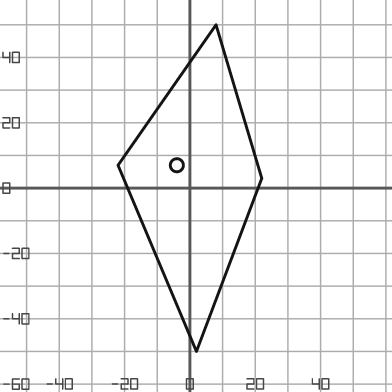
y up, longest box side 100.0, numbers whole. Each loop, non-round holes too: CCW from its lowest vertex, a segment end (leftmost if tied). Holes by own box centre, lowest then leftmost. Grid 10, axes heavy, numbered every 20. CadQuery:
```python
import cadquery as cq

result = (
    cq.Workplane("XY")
    .moveTo(2.0, -50.0)
    .lineTo(22.0, 3.0)
    .lineTo(8.0, 50.0)
    .lineTo(-22.0, 7.0)
    .close()
    .moveTo(-4.0, 7.0)
    .circle(2.0)
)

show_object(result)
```